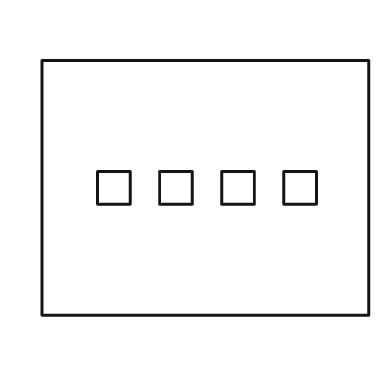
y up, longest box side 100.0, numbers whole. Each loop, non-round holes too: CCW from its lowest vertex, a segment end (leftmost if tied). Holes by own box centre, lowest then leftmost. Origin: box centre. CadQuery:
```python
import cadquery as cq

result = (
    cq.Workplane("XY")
    .moveTo(-50.0, -39.0)
    .lineTo(50.0, -39.0)
    .lineTo(50.0, 39.0)
    .lineTo(-50.0, 39.0)
    .close()
    .moveTo(-33.0, -5.0)
    .lineTo(-23.0, -5.0)
    .lineTo(-23.0, 5.0)
    .lineTo(-33.0, 5.0)
    .close()
    .moveTo(-14.0, -5.0)
    .lineTo(-4.0, -5.0)
    .lineTo(-4.0, 5.0)
    .lineTo(-14.0, 5.0)
    .close()
    .moveTo(5.0, -5.0)
    .lineTo(15.0, -5.0)
    .lineTo(15.0, 5.0)
    .lineTo(5.0, 5.0)
    .close()
    .moveTo(24.0, -5.0)
    .lineTo(34.0, -5.0)
    .lineTo(34.0, 5.0)
    .lineTo(24.0, 5.0)
    .close()
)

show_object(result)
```